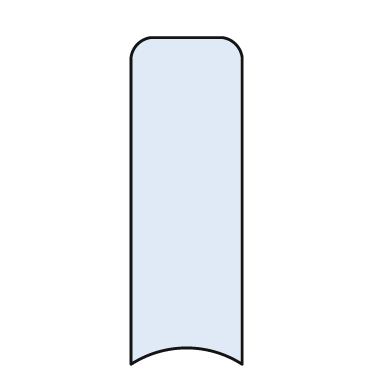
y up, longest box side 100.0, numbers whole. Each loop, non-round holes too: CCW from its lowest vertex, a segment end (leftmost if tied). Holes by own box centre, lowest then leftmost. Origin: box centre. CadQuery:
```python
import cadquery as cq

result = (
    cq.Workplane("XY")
    .moveTo(-17.0, -50.0)
    .threePointArc((0.0, -45.0), (17.0, -50.0))
    .lineTo(17.0, 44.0)
    .threePointArc((15.0, 48.0), (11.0, 50.0))
    .lineTo(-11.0, 50.0)
    .threePointArc((-15.0, 48.0), (-17.0, 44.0))
    .close()
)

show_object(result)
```